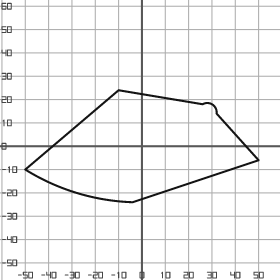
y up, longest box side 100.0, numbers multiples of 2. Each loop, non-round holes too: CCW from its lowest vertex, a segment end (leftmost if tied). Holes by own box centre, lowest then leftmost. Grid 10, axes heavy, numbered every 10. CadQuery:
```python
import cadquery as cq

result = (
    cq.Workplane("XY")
    .moveTo(-4.0, -24.0)
    .lineTo(50.0, -6.0)
    .lineTo(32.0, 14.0)
    .threePointArc((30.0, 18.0), (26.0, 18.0))
    .lineTo(-10.0, 24.0)
    .lineTo(-50.0, -10.0)
    .threePointArc((-28.0, -20.0), (-4.0, -24.0))
    .close()
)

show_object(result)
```